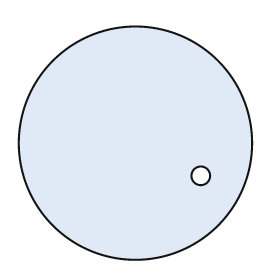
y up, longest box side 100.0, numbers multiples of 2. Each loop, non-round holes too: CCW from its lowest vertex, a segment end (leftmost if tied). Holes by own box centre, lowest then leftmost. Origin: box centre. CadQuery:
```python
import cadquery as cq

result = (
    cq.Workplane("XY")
    .moveTo(0.0, 0.0)
    .circle(50.0)
    .moveTo(28.0, -14.0)
    .circle(4.0)
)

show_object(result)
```